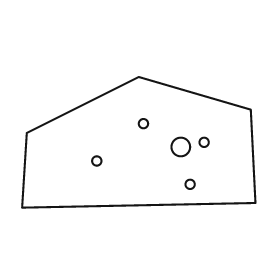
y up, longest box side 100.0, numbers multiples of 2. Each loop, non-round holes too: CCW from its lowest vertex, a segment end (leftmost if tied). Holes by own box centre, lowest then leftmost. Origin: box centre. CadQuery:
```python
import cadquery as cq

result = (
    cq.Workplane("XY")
    .moveTo(-50.0, -28.0)
    .lineTo(50.0, -26.0)
    .lineTo(48.0, 14.0)
    .lineTo(0.0, 28.0)
    .lineTo(-48.0, 4.0)
    .close()
    .moveTo(22.0, -18.0)
    .circle(2.0)
    .moveTo(-18.0, -8.0)
    .circle(2.0)
    .moveTo(18.0, -2.0)
    .circle(4.0)
    .moveTo(28.0, 0.0)
    .circle(2.0)
    .moveTo(2.0, 8.0)
    .circle(2.0)
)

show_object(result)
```